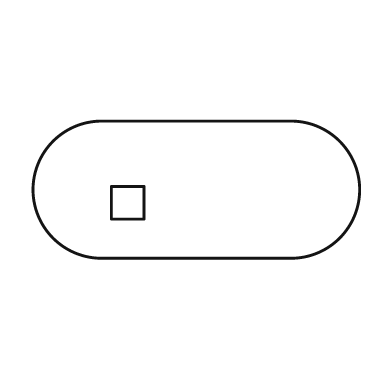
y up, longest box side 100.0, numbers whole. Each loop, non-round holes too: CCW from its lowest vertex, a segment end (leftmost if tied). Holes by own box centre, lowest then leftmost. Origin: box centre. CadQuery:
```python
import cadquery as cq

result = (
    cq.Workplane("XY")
    .moveTo(-29.0, -21.0)
    .lineTo(29.0, -21.0)
    .threePointArc((50.0, 0.0), (29.0, 21.0))
    .lineTo(-29.0, 21.0)
    .threePointArc((-50.0, 0.0), (-29.0, -21.0))
    .close()
    .moveTo(-26.0, -9.0)
    .lineTo(-16.0, -9.0)
    .lineTo(-16.0, 1.0)
    .lineTo(-26.0, 1.0)
    .close()
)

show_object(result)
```